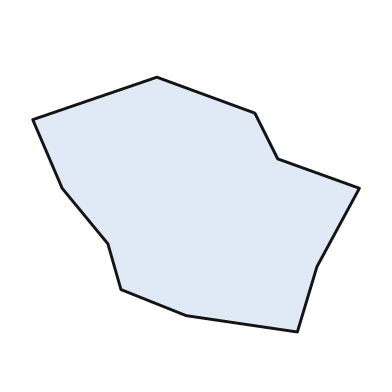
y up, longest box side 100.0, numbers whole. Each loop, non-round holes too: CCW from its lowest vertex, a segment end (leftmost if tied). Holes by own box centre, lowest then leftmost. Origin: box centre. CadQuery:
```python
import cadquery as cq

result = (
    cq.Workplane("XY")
    .moveTo(31.0, -39.0)
    .lineTo(37.0, -19.0)
    .lineTo(50.0, 5.0)
    .lineTo(25.0, 14.0)
    .lineTo(18.0, 28.0)
    .lineTo(-12.0, 39.0)
    .lineTo(-50.0, 26.0)
    .lineTo(-41.0, 5.0)
    .lineTo(-27.0, -12.0)
    .lineTo(-23.0, -26.0)
    .lineTo(-3.0, -34.0)
    .close()
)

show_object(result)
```